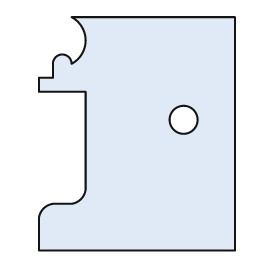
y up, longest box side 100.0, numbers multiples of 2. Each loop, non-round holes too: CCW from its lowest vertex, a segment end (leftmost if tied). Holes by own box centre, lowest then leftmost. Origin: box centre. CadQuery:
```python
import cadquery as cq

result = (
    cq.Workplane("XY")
    .moveTo(-42.0, -50.0)
    .lineTo(42.0, -50.0)
    .lineTo(42.0, 50.0)
    .lineTo(-28.0, 50.0)
    .threePointArc((-22.0, 40.0), (-28.0, 30.0))
    .threePointArc((-32.0, 34.0), (-36.0, 30.0))
    .lineTo(-36.0, 24.0)
    .lineTo(-42.0, 24.0)
    .lineTo(-42.0, 18.0)
    .lineTo(-22.0, 18.0)
    .lineTo(-22.0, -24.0)
    .threePointArc((-24.0, -28.0), (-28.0, -30.0))
    .lineTo(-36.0, -30.0)
    .threePointArc((-40.0, -32.0), (-42.0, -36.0))
    .close()
    .moveTo(20.0, 6.0)
    .circle(6.0)
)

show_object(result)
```